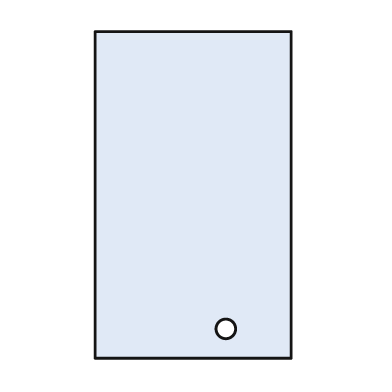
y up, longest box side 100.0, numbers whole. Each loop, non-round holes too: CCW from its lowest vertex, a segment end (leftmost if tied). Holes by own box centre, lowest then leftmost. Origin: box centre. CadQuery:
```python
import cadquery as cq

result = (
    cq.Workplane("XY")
    .moveTo(-30.0, -50.0)
    .lineTo(30.0, -50.0)
    .lineTo(30.0, 50.0)
    .lineTo(-30.0, 50.0)
    .close()
    .moveTo(10.0, -41.0)
    .circle(3.0)
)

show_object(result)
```